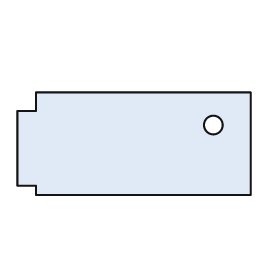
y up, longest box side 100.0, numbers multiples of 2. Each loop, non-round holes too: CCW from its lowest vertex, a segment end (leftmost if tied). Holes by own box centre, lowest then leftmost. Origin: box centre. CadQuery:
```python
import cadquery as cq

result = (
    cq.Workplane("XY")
    .moveTo(-42.0, -22.0)
    .lineTo(50.0, -22.0)
    .lineTo(50.0, 22.0)
    .lineTo(-42.0, 22.0)
    .lineTo(-42.0, 14.0)
    .lineTo(-50.0, 14.0)
    .lineTo(-50.0, -18.0)
    .lineTo(-42.0, -18.0)
    .close()
    .moveTo(34.0, 8.0)
    .circle(4.0)
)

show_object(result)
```